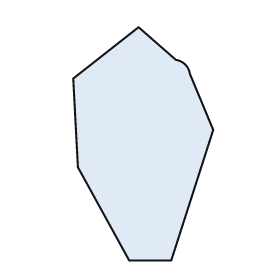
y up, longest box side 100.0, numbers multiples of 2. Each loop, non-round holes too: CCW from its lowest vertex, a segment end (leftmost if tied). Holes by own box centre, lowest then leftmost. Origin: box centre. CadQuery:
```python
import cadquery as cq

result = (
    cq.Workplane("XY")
    .moveTo(-6.0, -50.0)
    .lineTo(12.0, -50.0)
    .lineTo(30.0, 6.0)
    .lineTo(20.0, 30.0)
    .threePointArc((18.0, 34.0), (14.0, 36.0))
    .lineTo(-2.0, 50.0)
    .lineTo(-30.0, 28.0)
    .lineTo(-28.0, -10.0)
    .close()
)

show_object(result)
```